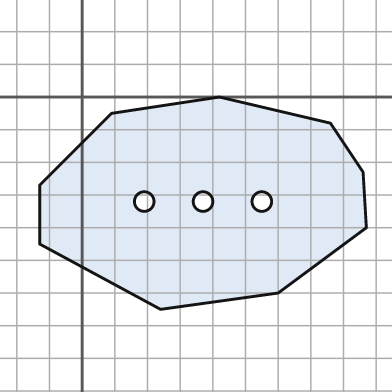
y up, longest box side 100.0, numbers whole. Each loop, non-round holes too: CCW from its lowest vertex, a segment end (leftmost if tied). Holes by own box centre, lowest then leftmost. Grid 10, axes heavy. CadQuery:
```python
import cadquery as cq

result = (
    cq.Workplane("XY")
    .moveTo(24.0, -65.0)
    .lineTo(60.0, -60.0)
    .lineTo(87.0, -40.0)
    .lineTo(86.0, -23.0)
    .lineTo(76.0, -8.0)
    .lineTo(42.0, 0.0)
    .lineTo(9.0, -5.0)
    .lineTo(-13.0, -27.0)
    .lineTo(-13.0, -45.0)
    .close()
    .moveTo(19.0, -32.0)
    .circle(3.0)
    .moveTo(37.0, -32.0)
    .circle(3.0)
    .moveTo(55.0, -32.0)
    .circle(3.0)
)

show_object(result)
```